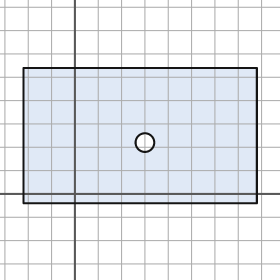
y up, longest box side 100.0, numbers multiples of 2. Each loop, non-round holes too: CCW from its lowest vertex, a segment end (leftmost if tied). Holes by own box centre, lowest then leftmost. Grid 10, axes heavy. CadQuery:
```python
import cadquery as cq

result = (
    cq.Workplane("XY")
    .moveTo(-22.0, -4.0)
    .lineTo(78.0, -4.0)
    .lineTo(78.0, 54.0)
    .lineTo(-22.0, 54.0)
    .close()
    .moveTo(30.0, 22.0)
    .circle(4.0)
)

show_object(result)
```